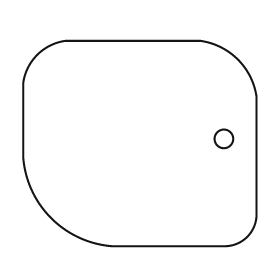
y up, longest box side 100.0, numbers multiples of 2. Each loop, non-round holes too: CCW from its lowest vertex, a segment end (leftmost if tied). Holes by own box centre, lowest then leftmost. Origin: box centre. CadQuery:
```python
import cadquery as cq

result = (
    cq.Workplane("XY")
    .moveTo(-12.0, -44.0)
    .lineTo(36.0, -44.0)
    .threePointArc((46.0, -40.0), (50.0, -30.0))
    .lineTo(50.0, 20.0)
    .threePointArc((42.0, 36.0), (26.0, 44.0))
    .lineTo(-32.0, 44.0)
    .threePointArc((-44.0, 38.0), (-50.0, 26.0))
    .lineTo(-50.0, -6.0)
    .threePointArc((-38.0, -32.0), (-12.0, -44.0))
    .close()
    .moveTo(36.0, 2.0)
    .circle(4.0)
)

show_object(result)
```